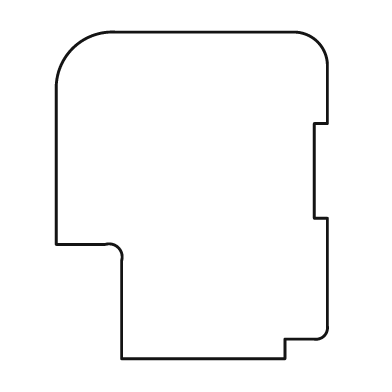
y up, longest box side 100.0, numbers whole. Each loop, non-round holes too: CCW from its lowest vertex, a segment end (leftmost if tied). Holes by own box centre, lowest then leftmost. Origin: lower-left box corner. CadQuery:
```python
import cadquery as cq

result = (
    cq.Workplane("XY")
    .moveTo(20.0, 0.0)
    .lineTo(70.0, 0.0)
    .lineTo(70.0, 6.0)
    .lineTo(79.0, 6.0)
    .threePointArc((82.0, 7.0), (83.0, 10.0))
    .lineTo(83.0, 43.0)
    .lineTo(79.0, 43.0)
    .lineTo(79.0, 72.0)
    .lineTo(83.0, 72.0)
    .lineTo(83.0, 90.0)
    .threePointArc((80.0, 97.0), (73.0, 100.0))
    .lineTo(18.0, 100.0)
    .threePointArc((5.0, 95.0), (0.0, 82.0))
    .lineTo(0.0, 35.0)
    .lineTo(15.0, 35.0)
    .threePointArc((19.0, 34.0), (20.0, 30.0))
    .close()
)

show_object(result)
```